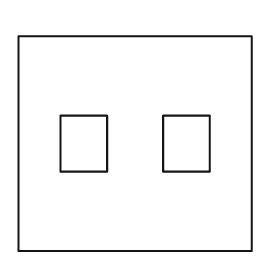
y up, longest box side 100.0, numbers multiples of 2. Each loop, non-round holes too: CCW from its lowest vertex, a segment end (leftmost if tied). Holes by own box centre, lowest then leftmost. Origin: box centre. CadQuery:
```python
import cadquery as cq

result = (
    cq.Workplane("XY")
    .moveTo(-50.0, -46.0)
    .lineTo(50.0, -46.0)
    .lineTo(50.0, 46.0)
    .lineTo(-50.0, 46.0)
    .close()
    .moveTo(-32.0, -12.0)
    .lineTo(-12.0, -12.0)
    .lineTo(-12.0, 12.0)
    .lineTo(-32.0, 12.0)
    .close()
    .moveTo(12.0, -12.0)
    .lineTo(32.0, -12.0)
    .lineTo(32.0, 12.0)
    .lineTo(12.0, 12.0)
    .close()
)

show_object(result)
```